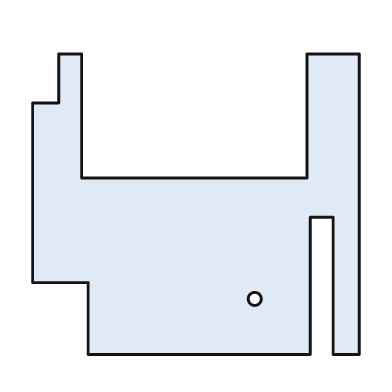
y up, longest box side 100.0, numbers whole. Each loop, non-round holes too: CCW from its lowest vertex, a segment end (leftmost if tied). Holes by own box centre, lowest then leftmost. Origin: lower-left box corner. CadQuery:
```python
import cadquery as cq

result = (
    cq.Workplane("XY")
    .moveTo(17.0, 0.0)
    .lineTo(85.0, 0.0)
    .lineTo(85.0, 42.0)
    .lineTo(92.0, 42.0)
    .lineTo(92.0, 0.0)
    .lineTo(100.0, 0.0)
    .lineTo(100.0, 92.0)
    .lineTo(84.0, 92.0)
    .lineTo(84.0, 54.0)
    .lineTo(15.0, 54.0)
    .lineTo(15.0, 92.0)
    .lineTo(8.0, 92.0)
    .lineTo(8.0, 77.0)
    .lineTo(0.0, 77.0)
    .lineTo(0.0, 22.0)
    .lineTo(17.0, 22.0)
    .close()
    .moveTo(68.0, 17.0)
    .circle(2.0)
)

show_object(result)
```